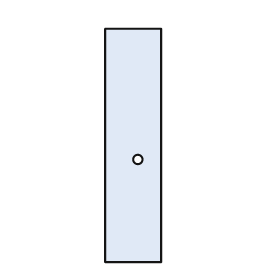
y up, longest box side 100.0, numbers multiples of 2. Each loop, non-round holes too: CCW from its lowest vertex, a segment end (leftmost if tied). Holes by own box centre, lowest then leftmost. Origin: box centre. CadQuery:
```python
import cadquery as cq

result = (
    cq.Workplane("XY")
    .moveTo(-12.0, -50.0)
    .lineTo(12.0, -50.0)
    .lineTo(12.0, 50.0)
    .lineTo(-12.0, 50.0)
    .close()
    .moveTo(2.0, -6.0)
    .circle(2.0)
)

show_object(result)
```